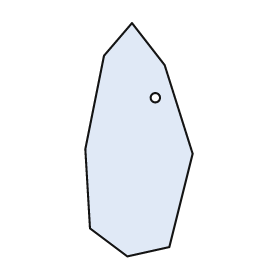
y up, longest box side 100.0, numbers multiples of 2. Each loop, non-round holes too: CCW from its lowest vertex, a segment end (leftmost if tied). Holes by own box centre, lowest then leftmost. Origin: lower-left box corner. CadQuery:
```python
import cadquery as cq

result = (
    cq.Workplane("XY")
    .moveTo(18.0, 0.0)
    .lineTo(36.0, 4.0)
    .lineTo(46.0, 44.0)
    .lineTo(34.0, 82.0)
    .lineTo(20.0, 100.0)
    .lineTo(8.0, 86.0)
    .lineTo(0.0, 46.0)
    .lineTo(2.0, 12.0)
    .close()
    .moveTo(30.0, 68.0)
    .circle(2.0)
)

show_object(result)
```